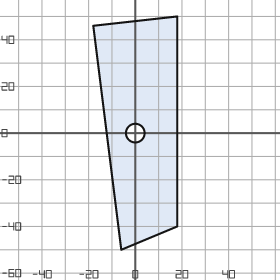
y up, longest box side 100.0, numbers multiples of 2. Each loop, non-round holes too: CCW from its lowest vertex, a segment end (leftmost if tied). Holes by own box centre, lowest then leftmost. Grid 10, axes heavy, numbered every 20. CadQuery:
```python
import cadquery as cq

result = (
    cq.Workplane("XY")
    .moveTo(-6.0, -50.0)
    .lineTo(18.0, -40.0)
    .lineTo(18.0, 50.0)
    .lineTo(-18.0, 46.0)
    .close()
    .moveTo(0.0, 0.0)
    .circle(4.0)
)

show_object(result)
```